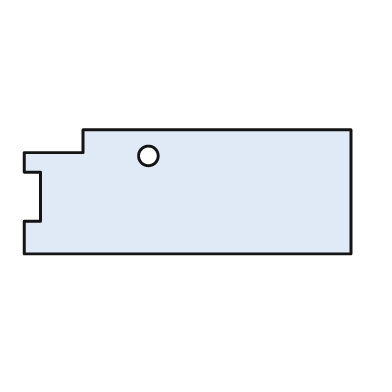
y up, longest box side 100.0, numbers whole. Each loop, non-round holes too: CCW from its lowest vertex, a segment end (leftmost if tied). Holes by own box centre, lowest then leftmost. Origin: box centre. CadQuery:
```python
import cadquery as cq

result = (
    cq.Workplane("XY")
    .moveTo(-50.0, -19.0)
    .lineTo(50.0, -19.0)
    .lineTo(50.0, 19.0)
    .lineTo(-32.0, 19.0)
    .lineTo(-32.0, 12.0)
    .lineTo(-50.0, 12.0)
    .lineTo(-50.0, 6.0)
    .lineTo(-45.0, 6.0)
    .lineTo(-45.0, -9.0)
    .lineTo(-50.0, -9.0)
    .close()
    .moveTo(-12.0, 11.0)
    .circle(3.0)
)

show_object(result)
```